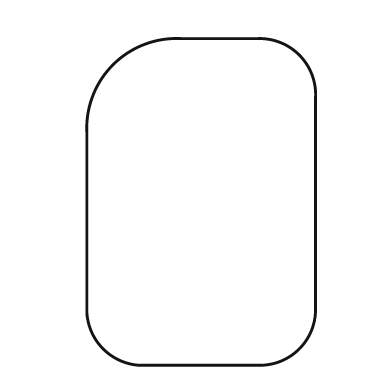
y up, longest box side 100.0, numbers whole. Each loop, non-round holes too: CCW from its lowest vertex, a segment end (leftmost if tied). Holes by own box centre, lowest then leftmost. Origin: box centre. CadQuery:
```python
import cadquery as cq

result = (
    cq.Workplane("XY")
    .moveTo(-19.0, -50.0)
    .lineTo(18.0, -50.0)
    .threePointArc((30.0, -45.0), (35.0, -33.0))
    .lineTo(35.0, 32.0)
    .threePointArc((30.0, 45.0), (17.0, 50.0))
    .lineTo(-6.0, 50.0)
    .threePointArc((-27.0, 42.0), (-35.0, 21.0))
    .lineTo(-35.0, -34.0)
    .threePointArc((-30.0, -45.0), (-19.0, -50.0))
    .close()
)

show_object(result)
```